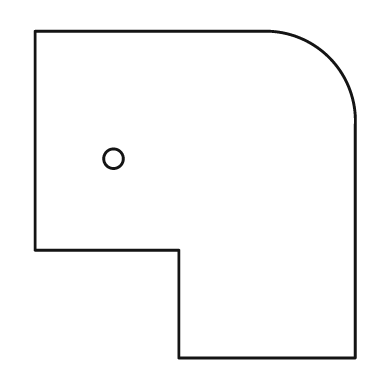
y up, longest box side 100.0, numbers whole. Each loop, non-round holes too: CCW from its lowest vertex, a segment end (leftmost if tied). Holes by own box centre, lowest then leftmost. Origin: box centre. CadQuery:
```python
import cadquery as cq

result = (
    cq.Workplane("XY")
    .moveTo(-5.0, -50.0)
    .lineTo(49.0, -50.0)
    .lineTo(49.0, 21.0)
    .threePointArc((41.0, 42.0), (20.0, 50.0))
    .lineTo(-49.0, 50.0)
    .lineTo(-49.0, -17.0)
    .lineTo(-5.0, -17.0)
    .close()
    .moveTo(-25.0, 11.0)
    .circle(3.0)
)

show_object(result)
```